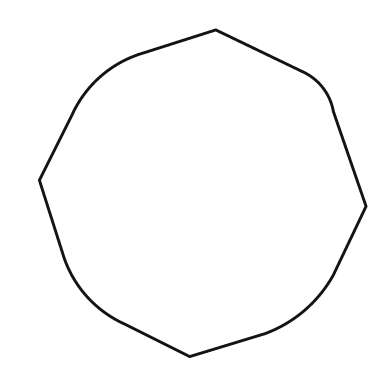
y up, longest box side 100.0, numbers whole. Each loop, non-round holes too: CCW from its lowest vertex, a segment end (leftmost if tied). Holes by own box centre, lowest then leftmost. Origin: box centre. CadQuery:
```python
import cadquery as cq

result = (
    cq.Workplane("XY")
    .moveTo(-4.0, -50.0)
    .lineTo(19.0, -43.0)
    .threePointArc((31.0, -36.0), (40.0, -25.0))
    .lineTo(50.0, -4.0)
    .lineTo(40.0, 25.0)
    .threePointArc((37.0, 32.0), (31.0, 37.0))
    .lineTo(4.0, 50.0)
    .lineTo(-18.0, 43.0)
    .threePointArc((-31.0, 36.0), (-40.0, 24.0))
    .lineTo(-50.0, 4.0)
    .lineTo(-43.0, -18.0)
    .threePointArc((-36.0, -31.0), (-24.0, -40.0))
    .close()
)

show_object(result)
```